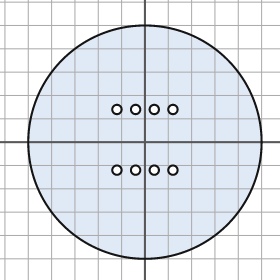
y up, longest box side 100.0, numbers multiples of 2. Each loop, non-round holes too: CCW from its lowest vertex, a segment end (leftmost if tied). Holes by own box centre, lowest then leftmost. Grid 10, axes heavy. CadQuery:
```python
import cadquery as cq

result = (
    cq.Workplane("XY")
    .moveTo(0.0, 0.0)
    .circle(50.0)
    .moveTo(-12.0, -12.0)
    .circle(2.0)
    .moveTo(-4.0, -12.0)
    .circle(2.0)
    .moveTo(4.0, -12.0)
    .circle(2.0)
    .moveTo(12.0, -12.0)
    .circle(2.0)
    .moveTo(-12.0, 14.0)
    .circle(2.0)
    .moveTo(-4.0, 14.0)
    .circle(2.0)
    .moveTo(4.0, 14.0)
    .circle(2.0)
    .moveTo(12.0, 14.0)
    .circle(2.0)
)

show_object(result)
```